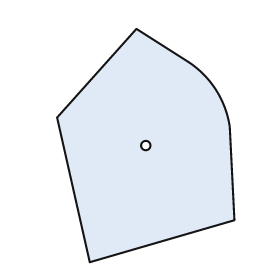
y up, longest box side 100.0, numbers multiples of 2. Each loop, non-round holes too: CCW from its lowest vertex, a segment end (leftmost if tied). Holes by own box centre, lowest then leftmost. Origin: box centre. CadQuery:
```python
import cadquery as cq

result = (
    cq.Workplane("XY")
    .moveTo(-24.0, -50.0)
    .lineTo(38.0, -32.0)
    .lineTo(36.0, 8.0)
    .threePointArc((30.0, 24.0), (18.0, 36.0))
    .lineTo(-4.0, 50.0)
    .lineTo(-38.0, 12.0)
    .close()
    .moveTo(0.0, 0.0)
    .circle(2.0)
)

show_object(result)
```